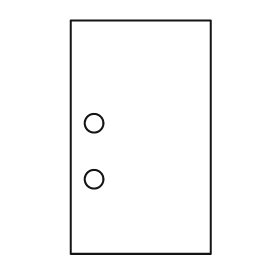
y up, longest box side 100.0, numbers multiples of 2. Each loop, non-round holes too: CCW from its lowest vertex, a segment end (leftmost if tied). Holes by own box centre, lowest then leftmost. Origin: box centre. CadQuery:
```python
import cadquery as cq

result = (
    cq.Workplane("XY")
    .moveTo(-30.0, -50.0)
    .lineTo(30.0, -50.0)
    .lineTo(30.0, 50.0)
    .lineTo(-30.0, 50.0)
    .close()
    .moveTo(-20.0, -18.0)
    .circle(4.0)
    .moveTo(-20.0, 6.0)
    .circle(4.0)
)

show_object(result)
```